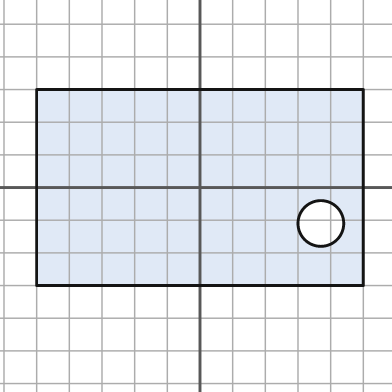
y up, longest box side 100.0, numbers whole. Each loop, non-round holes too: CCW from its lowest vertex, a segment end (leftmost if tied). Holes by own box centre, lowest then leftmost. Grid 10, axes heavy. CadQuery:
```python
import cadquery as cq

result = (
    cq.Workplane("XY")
    .moveTo(-50.0, -30.0)
    .lineTo(50.0, -30.0)
    .lineTo(50.0, 30.0)
    .lineTo(-50.0, 30.0)
    .close()
    .moveTo(37.0, -11.0)
    .circle(7.0)
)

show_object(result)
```